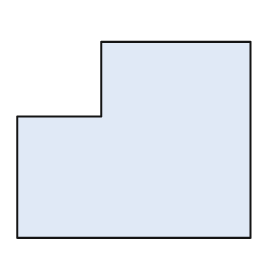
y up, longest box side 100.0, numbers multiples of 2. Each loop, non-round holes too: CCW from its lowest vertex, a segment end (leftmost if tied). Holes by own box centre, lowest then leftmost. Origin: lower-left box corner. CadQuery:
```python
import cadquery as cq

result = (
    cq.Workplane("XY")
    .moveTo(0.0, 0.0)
    .lineTo(100.0, 0.0)
    .lineTo(100.0, 84.0)
    .lineTo(36.0, 84.0)
    .lineTo(36.0, 52.0)
    .lineTo(0.0, 52.0)
    .close()
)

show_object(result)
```